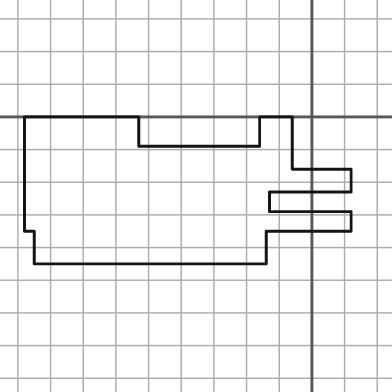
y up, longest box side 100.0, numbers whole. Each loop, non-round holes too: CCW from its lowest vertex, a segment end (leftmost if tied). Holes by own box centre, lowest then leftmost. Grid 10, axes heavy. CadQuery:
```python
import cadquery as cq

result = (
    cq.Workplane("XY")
    .moveTo(-85.0, -45.0)
    .lineTo(-14.0, -45.0)
    .lineTo(-14.0, -35.0)
    .lineTo(12.0, -35.0)
    .lineTo(12.0, -29.0)
    .lineTo(-13.0, -29.0)
    .lineTo(-13.0, -23.0)
    .lineTo(12.0, -23.0)
    .lineTo(12.0, -16.0)
    .lineTo(-6.0, -16.0)
    .lineTo(-6.0, 0.0)
    .lineTo(-16.0, 0.0)
    .lineTo(-16.0, -9.0)
    .lineTo(-53.0, -9.0)
    .lineTo(-53.0, 0.0)
    .lineTo(-88.0, 0.0)
    .lineTo(-88.0, -35.0)
    .lineTo(-85.0, -35.0)
    .close()
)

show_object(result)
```